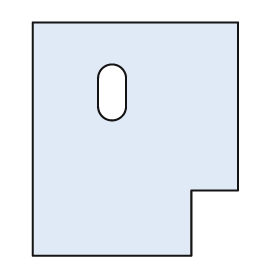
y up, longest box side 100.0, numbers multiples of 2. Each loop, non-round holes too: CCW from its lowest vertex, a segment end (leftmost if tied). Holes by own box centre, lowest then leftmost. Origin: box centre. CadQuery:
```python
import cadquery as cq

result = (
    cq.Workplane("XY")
    .moveTo(-44.0, -50.0)
    .lineTo(24.0, -50.0)
    .lineTo(24.0, -22.0)
    .lineTo(44.0, -22.0)
    .lineTo(44.0, 50.0)
    .lineTo(-44.0, 50.0)
    .close()
    .moveTo(-16.0, 14.0)
    .threePointArc((-10.0, 8.0), (-4.0, 14.0))
    .lineTo(-4.0, 26.0)
    .threePointArc((-10.0, 32.0), (-16.0, 26.0))
    .close()
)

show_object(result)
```